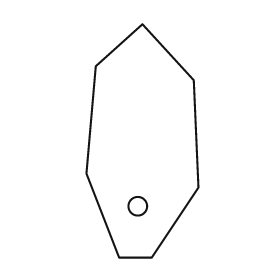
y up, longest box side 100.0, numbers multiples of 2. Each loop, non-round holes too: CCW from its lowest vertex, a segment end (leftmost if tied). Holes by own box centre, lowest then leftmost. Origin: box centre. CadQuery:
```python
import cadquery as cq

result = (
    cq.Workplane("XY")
    .moveTo(-10.0, -50.0)
    .lineTo(4.0, -50.0)
    .lineTo(24.0, -20.0)
    .lineTo(22.0, 26.0)
    .lineTo(0.0, 50.0)
    .lineTo(-20.0, 32.0)
    .lineTo(-24.0, -14.0)
    .close()
    .moveTo(-2.0, -28.0)
    .circle(4.0)
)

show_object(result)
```